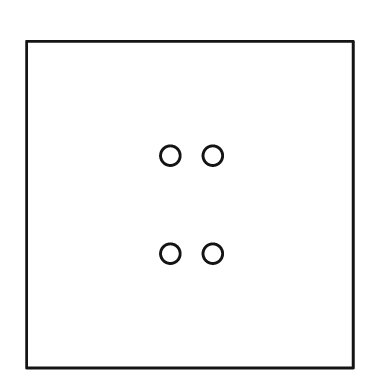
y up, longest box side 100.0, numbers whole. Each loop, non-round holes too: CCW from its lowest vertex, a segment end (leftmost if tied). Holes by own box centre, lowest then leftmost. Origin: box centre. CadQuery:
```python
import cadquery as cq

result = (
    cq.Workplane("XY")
    .moveTo(-50.0, -50.0)
    .lineTo(50.0, -50.0)
    .lineTo(50.0, 50.0)
    .lineTo(-50.0, 50.0)
    .close()
    .moveTo(-6.0, -15.0)
    .circle(3.0)
    .moveTo(7.0, -15.0)
    .circle(3.0)
    .moveTo(-6.0, 15.0)
    .circle(3.0)
    .moveTo(7.0, 15.0)
    .circle(3.0)
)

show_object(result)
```